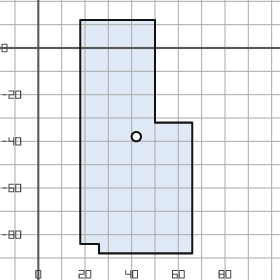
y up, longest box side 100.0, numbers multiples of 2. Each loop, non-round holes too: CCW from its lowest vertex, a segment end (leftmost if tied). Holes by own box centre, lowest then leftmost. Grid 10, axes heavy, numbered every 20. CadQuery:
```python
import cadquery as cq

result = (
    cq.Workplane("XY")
    .moveTo(26.0, -88.0)
    .lineTo(66.0, -88.0)
    .lineTo(66.0, -32.0)
    .lineTo(50.0, -32.0)
    .lineTo(50.0, 12.0)
    .lineTo(18.0, 12.0)
    .lineTo(18.0, -84.0)
    .lineTo(26.0, -84.0)
    .close()
    .moveTo(42.0, -38.0)
    .circle(2.0)
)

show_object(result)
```